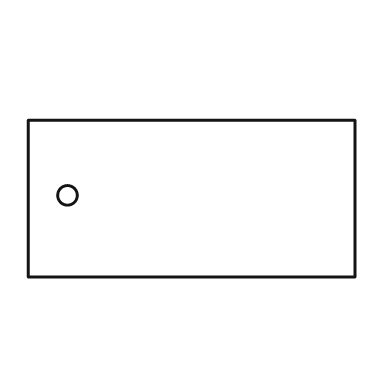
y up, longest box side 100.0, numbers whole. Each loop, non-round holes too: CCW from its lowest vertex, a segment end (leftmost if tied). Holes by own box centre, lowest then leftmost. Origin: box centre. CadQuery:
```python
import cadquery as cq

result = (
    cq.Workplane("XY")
    .moveTo(-50.0, -24.0)
    .lineTo(50.0, -24.0)
    .lineTo(50.0, 24.0)
    .lineTo(-50.0, 24.0)
    .close()
    .moveTo(-38.0, 1.0)
    .circle(3.0)
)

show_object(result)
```